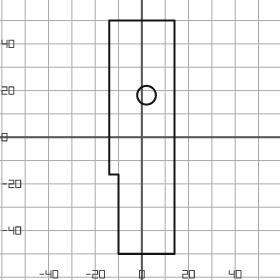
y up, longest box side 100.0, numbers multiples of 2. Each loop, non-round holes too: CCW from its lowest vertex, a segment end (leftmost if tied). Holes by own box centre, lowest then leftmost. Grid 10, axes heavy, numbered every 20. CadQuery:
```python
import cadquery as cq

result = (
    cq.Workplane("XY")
    .moveTo(-10.0, -50.0)
    .lineTo(14.0, -50.0)
    .lineTo(14.0, 50.0)
    .lineTo(-14.0, 50.0)
    .lineTo(-14.0, -16.0)
    .lineTo(-10.0, -16.0)
    .close()
    .moveTo(2.0, 18.0)
    .circle(4.0)
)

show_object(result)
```